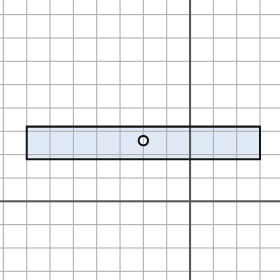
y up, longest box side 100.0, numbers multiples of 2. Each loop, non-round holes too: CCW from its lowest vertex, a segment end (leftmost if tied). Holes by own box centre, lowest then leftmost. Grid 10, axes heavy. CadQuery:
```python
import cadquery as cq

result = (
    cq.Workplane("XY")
    .moveTo(-70.0, 18.0)
    .lineTo(30.0, 18.0)
    .lineTo(30.0, 32.0)
    .lineTo(-70.0, 32.0)
    .close()
    .moveTo(-20.0, 26.0)
    .circle(2.0)
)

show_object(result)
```